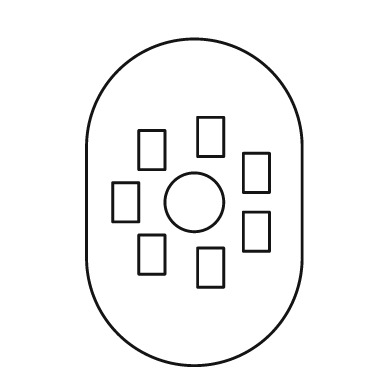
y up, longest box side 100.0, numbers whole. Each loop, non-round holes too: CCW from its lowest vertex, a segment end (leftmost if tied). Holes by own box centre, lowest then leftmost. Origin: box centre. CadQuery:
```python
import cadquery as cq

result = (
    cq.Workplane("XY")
    .moveTo(-33.0, -17.0)
    .threePointArc((0.0, -50.0), (33.0, -17.0))
    .lineTo(33.0, 17.0)
    .threePointArc((0.0, 50.0), (-33.0, 17.0))
    .close()
    .moveTo(1.0, -26.0)
    .lineTo(9.0, -26.0)
    .lineTo(9.0, -14.0)
    .lineTo(1.0, -14.0)
    .close()
    .moveTo(-17.0, -22.0)
    .lineTo(-9.0, -22.0)
    .lineTo(-9.0, -10.0)
    .lineTo(-17.0, -10.0)
    .close()
    .moveTo(15.0, -15.0)
    .lineTo(23.0, -15.0)
    .lineTo(23.0, -3.0)
    .lineTo(15.0, -3.0)
    .close()
    .moveTo(-25.0, -6.0)
    .lineTo(-17.0, -6.0)
    .lineTo(-17.0, 6.0)
    .lineTo(-25.0, 6.0)
    .close()
    .moveTo(0.0, 0.0)
    .circle(9.0)
    .moveTo(15.0, 3.0)
    .lineTo(23.0, 3.0)
    .lineTo(23.0, 15.0)
    .lineTo(15.0, 15.0)
    .close()
    .moveTo(-17.0, 10.0)
    .lineTo(-9.0, 10.0)
    .lineTo(-9.0, 22.0)
    .lineTo(-17.0, 22.0)
    .close()
    .moveTo(1.0, 14.0)
    .lineTo(9.0, 14.0)
    .lineTo(9.0, 26.0)
    .lineTo(1.0, 26.0)
    .close()
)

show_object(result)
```